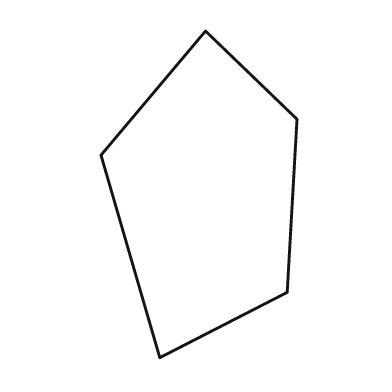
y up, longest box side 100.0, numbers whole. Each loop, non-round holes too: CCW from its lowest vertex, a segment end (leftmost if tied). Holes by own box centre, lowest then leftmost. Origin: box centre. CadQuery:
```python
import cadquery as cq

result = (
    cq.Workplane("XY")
    .moveTo(-12.0, -50.0)
    .lineTo(27.0, -30.0)
    .lineTo(30.0, 23.0)
    .lineTo(2.0, 50.0)
    .lineTo(-30.0, 12.0)
    .close()
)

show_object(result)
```